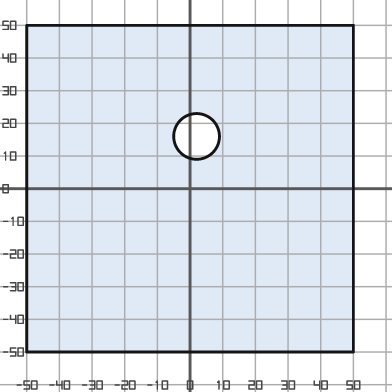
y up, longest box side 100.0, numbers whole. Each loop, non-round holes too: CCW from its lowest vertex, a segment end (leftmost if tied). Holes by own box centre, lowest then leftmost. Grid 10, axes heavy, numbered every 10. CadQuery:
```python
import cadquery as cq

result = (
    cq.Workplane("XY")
    .moveTo(-50.0, -50.0)
    .lineTo(50.0, -50.0)
    .lineTo(50.0, 50.0)
    .lineTo(-50.0, 50.0)
    .close()
    .moveTo(2.0, 16.0)
    .circle(7.0)
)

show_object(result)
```